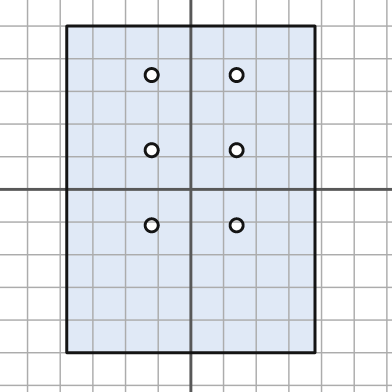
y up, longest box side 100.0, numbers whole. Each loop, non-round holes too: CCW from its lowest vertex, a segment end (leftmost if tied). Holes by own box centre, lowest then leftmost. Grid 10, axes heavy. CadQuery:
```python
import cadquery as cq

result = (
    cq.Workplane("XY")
    .moveTo(-38.0, -50.0)
    .lineTo(38.0, -50.0)
    .lineTo(38.0, 50.0)
    .lineTo(-38.0, 50.0)
    .close()
    .moveTo(-12.0, -11.0)
    .circle(2.0)
    .moveTo(14.0, -11.0)
    .circle(2.0)
    .moveTo(-12.0, 12.0)
    .circle(2.0)
    .moveTo(14.0, 12.0)
    .circle(2.0)
    .moveTo(-12.0, 35.0)
    .circle(2.0)
    .moveTo(14.0, 35.0)
    .circle(2.0)
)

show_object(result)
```